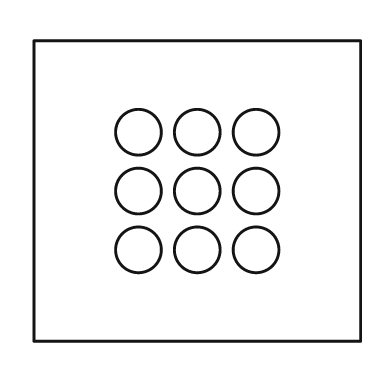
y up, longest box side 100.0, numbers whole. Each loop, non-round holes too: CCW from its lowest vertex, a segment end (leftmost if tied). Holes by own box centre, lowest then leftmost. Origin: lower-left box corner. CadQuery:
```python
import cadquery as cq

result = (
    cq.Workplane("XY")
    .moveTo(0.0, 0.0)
    .lineTo(100.0, 0.0)
    .lineTo(100.0, 92.0)
    .lineTo(0.0, 92.0)
    .close()
    .moveTo(32.0, 28.0)
    .circle(7.0)
    .moveTo(50.0, 28.0)
    .circle(7.0)
    .moveTo(68.0, 28.0)
    .circle(7.0)
    .moveTo(32.0, 46.0)
    .circle(7.0)
    .moveTo(50.0, 46.0)
    .circle(7.0)
    .moveTo(68.0, 46.0)
    .circle(7.0)
    .moveTo(32.0, 64.0)
    .circle(7.0)
    .moveTo(50.0, 64.0)
    .circle(7.0)
    .moveTo(68.0, 64.0)
    .circle(7.0)
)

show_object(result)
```